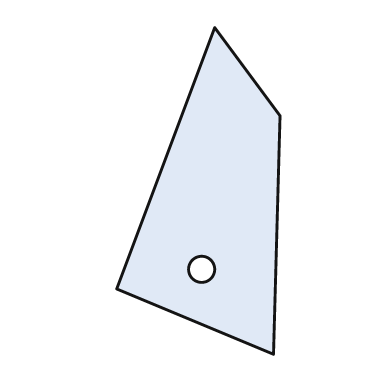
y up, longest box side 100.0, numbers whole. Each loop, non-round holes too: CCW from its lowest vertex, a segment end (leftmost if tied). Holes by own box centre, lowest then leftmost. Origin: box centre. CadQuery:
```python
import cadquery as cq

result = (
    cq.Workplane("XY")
    .moveTo(23.0, -50.0)
    .lineTo(25.0, 23.0)
    .lineTo(5.0, 50.0)
    .lineTo(-25.0, -30.0)
    .close()
    .moveTo(1.0, -24.0)
    .circle(4.0)
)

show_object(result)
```